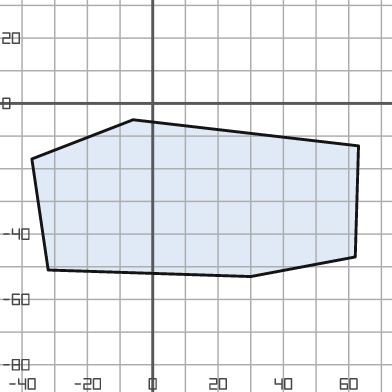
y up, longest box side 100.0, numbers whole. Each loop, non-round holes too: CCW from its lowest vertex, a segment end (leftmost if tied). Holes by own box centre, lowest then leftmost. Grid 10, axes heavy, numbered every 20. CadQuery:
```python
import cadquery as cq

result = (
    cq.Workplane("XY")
    .moveTo(30.0, -53.0)
    .lineTo(62.0, -47.0)
    .lineTo(63.0, -13.0)
    .lineTo(-6.0, -5.0)
    .lineTo(-37.0, -17.0)
    .lineTo(-32.0, -51.0)
    .close()
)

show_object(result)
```